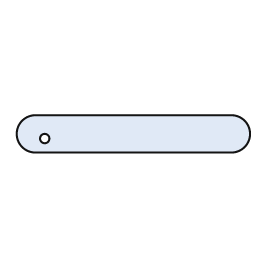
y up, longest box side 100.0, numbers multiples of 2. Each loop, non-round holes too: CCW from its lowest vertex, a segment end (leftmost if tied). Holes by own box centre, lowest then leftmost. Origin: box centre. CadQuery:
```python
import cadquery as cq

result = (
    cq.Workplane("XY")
    .moveTo(-42.0, -8.0)
    .lineTo(42.0, -8.0)
    .threePointArc((50.0, 0.0), (42.0, 8.0))
    .lineTo(-42.0, 8.0)
    .threePointArc((-50.0, 0.0), (-42.0, -8.0))
    .close()
    .moveTo(-38.0, -2.0)
    .circle(2.0)
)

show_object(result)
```